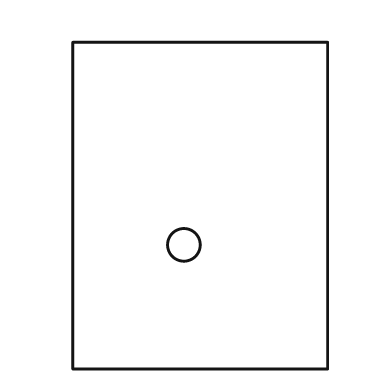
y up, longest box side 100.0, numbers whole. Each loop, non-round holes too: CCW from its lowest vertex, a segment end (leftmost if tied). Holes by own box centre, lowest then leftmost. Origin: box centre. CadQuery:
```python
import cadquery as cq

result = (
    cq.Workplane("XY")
    .moveTo(-39.0, -50.0)
    .lineTo(39.0, -50.0)
    .lineTo(39.0, 50.0)
    .lineTo(-39.0, 50.0)
    .close()
    .moveTo(-5.0, -12.0)
    .circle(5.0)
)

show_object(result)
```